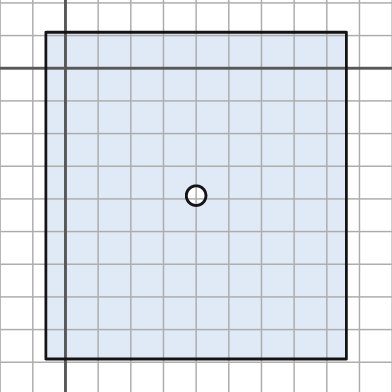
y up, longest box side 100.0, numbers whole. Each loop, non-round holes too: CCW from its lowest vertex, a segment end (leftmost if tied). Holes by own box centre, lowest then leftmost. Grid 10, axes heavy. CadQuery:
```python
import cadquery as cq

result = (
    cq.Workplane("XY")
    .moveTo(-6.0, -89.0)
    .lineTo(86.0, -89.0)
    .lineTo(86.0, 11.0)
    .lineTo(-6.0, 11.0)
    .close()
    .moveTo(40.0, -39.0)
    .circle(3.0)
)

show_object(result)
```